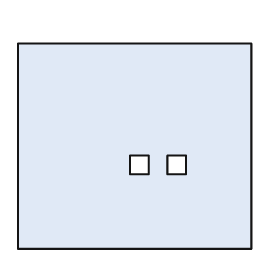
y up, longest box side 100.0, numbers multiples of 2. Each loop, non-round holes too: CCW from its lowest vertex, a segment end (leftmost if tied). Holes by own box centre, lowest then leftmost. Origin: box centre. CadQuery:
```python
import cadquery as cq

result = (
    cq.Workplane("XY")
    .moveTo(-50.0, -44.0)
    .lineTo(50.0, -44.0)
    .lineTo(50.0, 44.0)
    .lineTo(-50.0, 44.0)
    .close()
    .moveTo(-2.0, -12.0)
    .lineTo(6.0, -12.0)
    .lineTo(6.0, -4.0)
    .lineTo(-2.0, -4.0)
    .close()
    .moveTo(14.0, -12.0)
    .lineTo(22.0, -12.0)
    .lineTo(22.0, -4.0)
    .lineTo(14.0, -4.0)
    .close()
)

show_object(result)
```